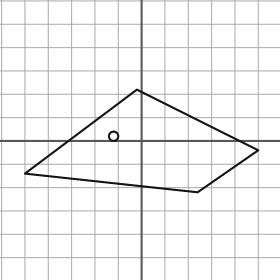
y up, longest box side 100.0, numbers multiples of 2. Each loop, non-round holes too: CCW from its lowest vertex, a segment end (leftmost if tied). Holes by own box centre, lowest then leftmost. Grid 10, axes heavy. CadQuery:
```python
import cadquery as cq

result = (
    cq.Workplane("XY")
    .moveTo(24.0, -22.0)
    .lineTo(50.0, -4.0)
    .lineTo(-2.0, 22.0)
    .lineTo(-50.0, -14.0)
    .close()
    .moveTo(-12.0, 2.0)
    .circle(2.0)
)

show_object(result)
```